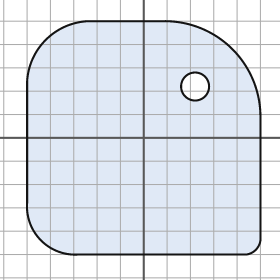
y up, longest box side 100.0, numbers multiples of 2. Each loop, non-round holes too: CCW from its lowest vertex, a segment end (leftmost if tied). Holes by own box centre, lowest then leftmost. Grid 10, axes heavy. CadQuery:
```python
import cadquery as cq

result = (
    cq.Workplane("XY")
    .moveTo(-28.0, -50.0)
    .lineTo(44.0, -50.0)
    .threePointArc((48.0, -48.0), (50.0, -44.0))
    .lineTo(50.0, 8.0)
    .threePointArc((38.0, 38.0), (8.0, 50.0))
    .lineTo(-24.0, 50.0)
    .threePointArc((-42.0, 42.0), (-50.0, 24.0))
    .lineTo(-50.0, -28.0)
    .threePointArc((-44.0, -44.0), (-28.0, -50.0))
    .close()
    .moveTo(22.0, 22.0)
    .circle(6.0)
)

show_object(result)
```